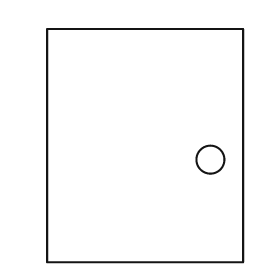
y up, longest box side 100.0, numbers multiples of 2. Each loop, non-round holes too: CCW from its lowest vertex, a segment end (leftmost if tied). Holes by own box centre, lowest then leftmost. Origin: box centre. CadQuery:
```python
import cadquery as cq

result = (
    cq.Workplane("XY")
    .moveTo(-42.0, -50.0)
    .lineTo(42.0, -50.0)
    .lineTo(42.0, 50.0)
    .lineTo(-42.0, 50.0)
    .close()
    .moveTo(28.0, -6.0)
    .circle(6.0)
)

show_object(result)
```